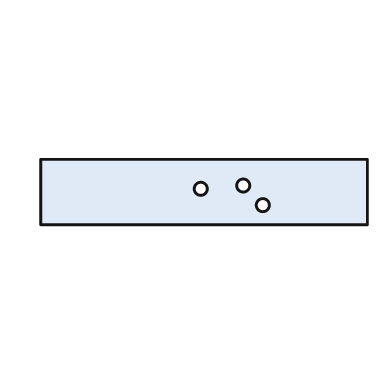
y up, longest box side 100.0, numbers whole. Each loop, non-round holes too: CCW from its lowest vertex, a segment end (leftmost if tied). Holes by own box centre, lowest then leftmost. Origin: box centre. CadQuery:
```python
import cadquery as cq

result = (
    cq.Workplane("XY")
    .moveTo(-50.0, -10.0)
    .lineTo(50.0, -10.0)
    .lineTo(50.0, 10.0)
    .lineTo(-50.0, 10.0)
    .close()
    .moveTo(18.0, -4.0)
    .circle(2.0)
    .moveTo(-1.0, 1.0)
    .circle(2.0)
    .moveTo(12.0, 2.0)
    .circle(2.0)
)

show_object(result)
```